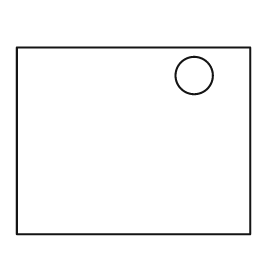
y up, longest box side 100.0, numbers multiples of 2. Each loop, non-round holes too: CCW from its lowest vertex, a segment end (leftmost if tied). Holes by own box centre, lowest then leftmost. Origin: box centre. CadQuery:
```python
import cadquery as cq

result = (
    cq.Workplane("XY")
    .moveTo(-50.0, -40.0)
    .lineTo(50.0, -40.0)
    .lineTo(50.0, 40.0)
    .lineTo(-50.0, 40.0)
    .close()
    .moveTo(26.0, 28.0)
    .circle(8.0)
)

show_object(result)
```